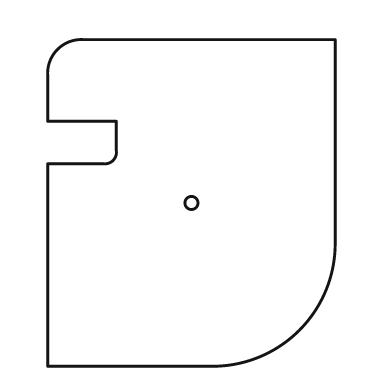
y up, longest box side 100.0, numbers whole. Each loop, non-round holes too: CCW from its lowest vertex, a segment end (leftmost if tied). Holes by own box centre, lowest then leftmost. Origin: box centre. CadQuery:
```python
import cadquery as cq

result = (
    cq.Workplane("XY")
    .moveTo(-44.0, -50.0)
    .lineTo(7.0, -50.0)
    .threePointArc((33.0, -39.0), (44.0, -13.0))
    .lineTo(44.0, 50.0)
    .lineTo(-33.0, 50.0)
    .threePointArc((-41.0, 47.0), (-44.0, 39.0))
    .lineTo(-44.0, 25.0)
    .lineTo(-23.0, 25.0)
    .lineTo(-23.0, 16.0)
    .threePointArc((-24.0, 13.0), (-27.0, 12.0))
    .lineTo(-44.0, 12.0)
    .close()
    .moveTo(0.0, 0.0)
    .circle(2.0)
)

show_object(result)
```